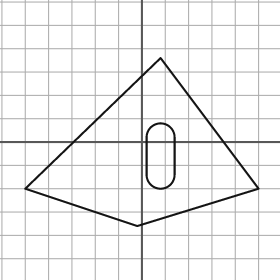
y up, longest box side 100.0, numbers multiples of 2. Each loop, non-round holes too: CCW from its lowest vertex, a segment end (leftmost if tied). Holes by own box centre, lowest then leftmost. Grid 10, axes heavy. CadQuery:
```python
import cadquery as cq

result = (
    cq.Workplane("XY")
    .moveTo(-2.0, -36.0)
    .lineTo(50.0, -20.0)
    .lineTo(8.0, 36.0)
    .lineTo(-50.0, -20.0)
    .close()
    .moveTo(2.0, -14.0)
    .threePointArc((8.0, -20.0), (14.0, -14.0))
    .lineTo(14.0, 2.0)
    .threePointArc((8.0, 8.0), (2.0, 2.0))
    .close()
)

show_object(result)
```